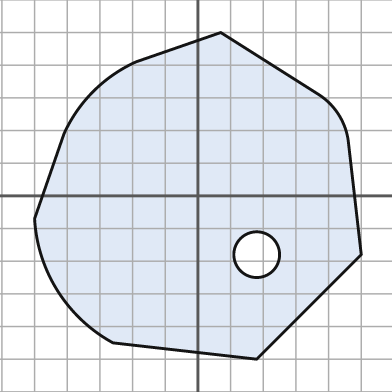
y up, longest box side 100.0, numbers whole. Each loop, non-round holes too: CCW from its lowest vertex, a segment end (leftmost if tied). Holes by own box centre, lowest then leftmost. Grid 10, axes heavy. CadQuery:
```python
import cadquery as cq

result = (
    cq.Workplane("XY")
    .moveTo(18.0, -50.0)
    .lineTo(50.0, -18.0)
    .lineTo(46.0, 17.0)
    .threePointArc((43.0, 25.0), (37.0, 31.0))
    .lineTo(7.0, 50.0)
    .lineTo(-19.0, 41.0)
    .threePointArc((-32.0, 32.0), (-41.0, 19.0))
    .lineTo(-50.0, -7.0)
    .threePointArc((-43.0, -29.0), (-26.0, -45.0))
    .close()
    .moveTo(18.0, -18.0)
    .circle(7.0)
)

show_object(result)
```